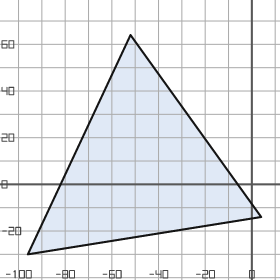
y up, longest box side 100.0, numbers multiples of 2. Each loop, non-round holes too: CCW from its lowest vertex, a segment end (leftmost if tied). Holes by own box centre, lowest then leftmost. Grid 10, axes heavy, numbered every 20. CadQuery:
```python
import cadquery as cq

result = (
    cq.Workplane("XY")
    .moveTo(-96.0, -30.0)
    .lineTo(4.0, -14.0)
    .lineTo(-52.0, 64.0)
    .close()
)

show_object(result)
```